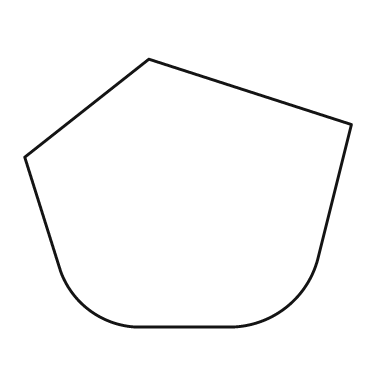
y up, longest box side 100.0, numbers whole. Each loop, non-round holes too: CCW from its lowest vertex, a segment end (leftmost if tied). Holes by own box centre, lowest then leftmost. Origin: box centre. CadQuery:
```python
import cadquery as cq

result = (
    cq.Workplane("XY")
    .moveTo(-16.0, -41.0)
    .lineTo(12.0, -41.0)
    .threePointArc((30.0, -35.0), (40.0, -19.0))
    .lineTo(50.0, 21.0)
    .lineTo(-12.0, 41.0)
    .lineTo(-50.0, 11.0)
    .lineTo(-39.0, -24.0)
    .threePointArc((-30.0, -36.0), (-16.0, -41.0))
    .close()
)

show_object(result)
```